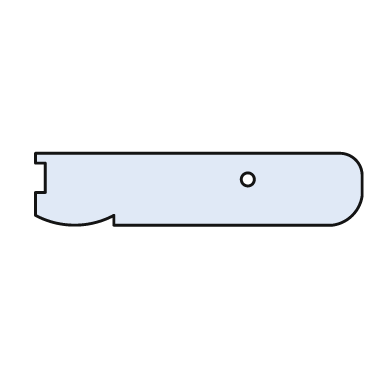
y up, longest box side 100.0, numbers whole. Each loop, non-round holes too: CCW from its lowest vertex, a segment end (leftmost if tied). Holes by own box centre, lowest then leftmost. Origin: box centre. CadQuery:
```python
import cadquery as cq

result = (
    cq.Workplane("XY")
    .moveTo(-26.0, -11.0)
    .lineTo(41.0, -11.0)
    .threePointArc((47.0, -8.0), (50.0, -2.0))
    .lineTo(50.0, 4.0)
    .threePointArc((48.0, 9.0), (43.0, 11.0))
    .lineTo(-50.0, 11.0)
    .lineTo(-50.0, 8.0)
    .lineTo(-47.0, 8.0)
    .lineTo(-47.0, -1.0)
    .lineTo(-50.0, -1.0)
    .lineTo(-50.0, -8.0)
    .threePointArc((-38.0, -11.0), (-26.0, -8.0))
    .close()
    .moveTo(15.0, 3.0)
    .circle(2.0)
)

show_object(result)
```